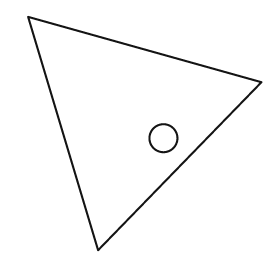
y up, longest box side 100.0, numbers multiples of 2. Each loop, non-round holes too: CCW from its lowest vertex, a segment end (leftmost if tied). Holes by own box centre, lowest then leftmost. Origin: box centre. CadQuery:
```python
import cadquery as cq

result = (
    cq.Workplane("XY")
    .moveTo(-20.0, -50.0)
    .lineTo(50.0, 22.0)
    .lineTo(-50.0, 50.0)
    .close()
    .moveTo(8.0, -2.0)
    .circle(6.0)
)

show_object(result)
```